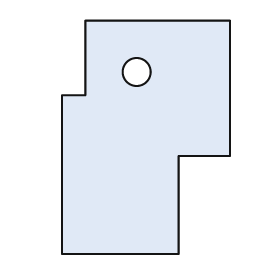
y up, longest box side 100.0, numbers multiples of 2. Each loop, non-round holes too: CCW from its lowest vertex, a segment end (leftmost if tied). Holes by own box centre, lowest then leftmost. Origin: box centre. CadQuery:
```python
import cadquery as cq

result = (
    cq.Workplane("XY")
    .moveTo(-36.0, -50.0)
    .lineTo(14.0, -50.0)
    .lineTo(14.0, -8.0)
    .lineTo(36.0, -8.0)
    .lineTo(36.0, 50.0)
    .lineTo(-26.0, 50.0)
    .lineTo(-26.0, 18.0)
    .lineTo(-36.0, 18.0)
    .close()
    .moveTo(-4.0, 28.0)
    .circle(6.0)
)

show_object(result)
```